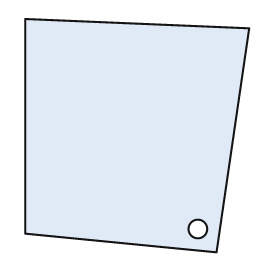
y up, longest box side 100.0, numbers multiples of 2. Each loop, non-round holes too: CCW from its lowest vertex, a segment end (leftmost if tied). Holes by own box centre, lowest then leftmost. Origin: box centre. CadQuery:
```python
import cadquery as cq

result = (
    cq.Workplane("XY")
    .moveTo(34.0, -50.0)
    .lineTo(48.0, 46.0)
    .lineTo(-48.0, 50.0)
    .lineTo(-48.0, -42.0)
    .close()
    .moveTo(26.0, -40.0)
    .circle(4.0)
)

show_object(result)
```